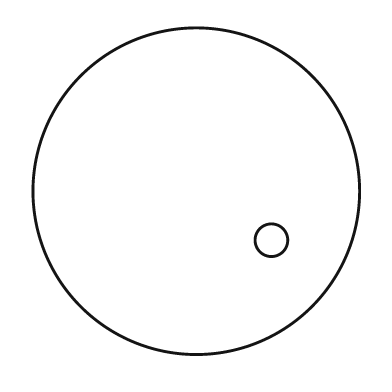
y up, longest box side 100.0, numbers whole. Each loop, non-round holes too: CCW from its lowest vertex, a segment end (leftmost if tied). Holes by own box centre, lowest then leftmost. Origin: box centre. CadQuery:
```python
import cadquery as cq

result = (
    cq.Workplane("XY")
    .moveTo(0.0, 0.0)
    .circle(50.0)
    .moveTo(23.0, -15.0)
    .circle(5.0)
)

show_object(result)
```